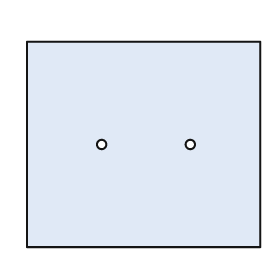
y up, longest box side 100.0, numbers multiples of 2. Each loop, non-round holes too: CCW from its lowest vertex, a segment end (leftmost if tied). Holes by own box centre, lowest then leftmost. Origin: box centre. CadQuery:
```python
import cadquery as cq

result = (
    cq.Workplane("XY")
    .moveTo(-50.0, -44.0)
    .lineTo(50.0, -44.0)
    .lineTo(50.0, 44.0)
    .lineTo(-50.0, 44.0)
    .close()
    .moveTo(-18.0, 0.0)
    .circle(2.0)
    .moveTo(20.0, 0.0)
    .circle(2.0)
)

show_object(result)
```